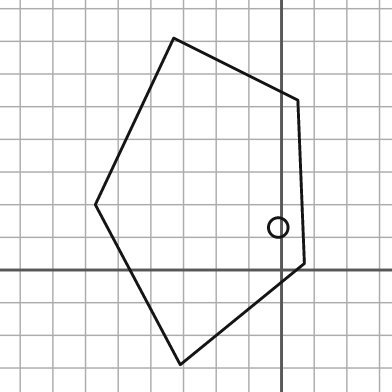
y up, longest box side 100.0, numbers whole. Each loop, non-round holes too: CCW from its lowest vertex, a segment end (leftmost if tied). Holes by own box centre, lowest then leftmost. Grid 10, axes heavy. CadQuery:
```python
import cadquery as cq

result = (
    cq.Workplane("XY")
    .moveTo(-31.0, -29.0)
    .lineTo(7.0, 2.0)
    .lineTo(5.0, 52.0)
    .lineTo(-33.0, 71.0)
    .lineTo(-57.0, 20.0)
    .close()
    .moveTo(-1.0, 13.0)
    .circle(3.0)
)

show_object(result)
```